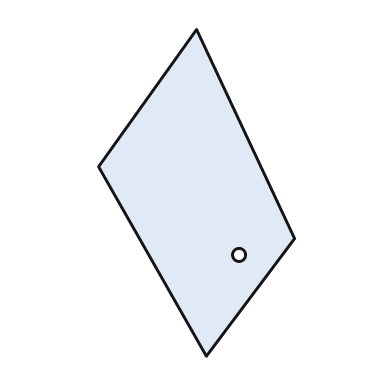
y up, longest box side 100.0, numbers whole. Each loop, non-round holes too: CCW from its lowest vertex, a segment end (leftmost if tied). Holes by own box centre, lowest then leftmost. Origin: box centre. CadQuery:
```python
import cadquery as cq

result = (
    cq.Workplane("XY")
    .moveTo(3.0, -50.0)
    .lineTo(30.0, -14.0)
    .lineTo(0.0, 50.0)
    .lineTo(-30.0, 8.0)
    .close()
    .moveTo(13.0, -19.0)
    .circle(2.0)
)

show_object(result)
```